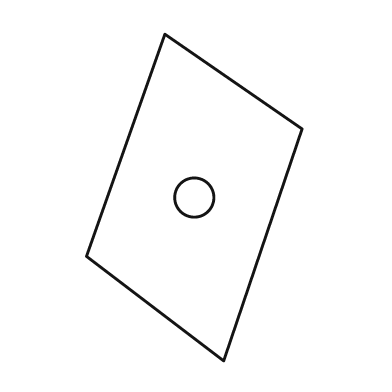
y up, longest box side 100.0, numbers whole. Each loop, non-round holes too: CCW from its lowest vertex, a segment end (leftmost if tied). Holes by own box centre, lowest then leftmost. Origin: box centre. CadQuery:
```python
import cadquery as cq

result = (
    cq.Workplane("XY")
    .moveTo(9.0, -50.0)
    .lineTo(33.0, 21.0)
    .lineTo(-9.0, 50.0)
    .lineTo(-33.0, -18.0)
    .close()
    .moveTo(0.0, 0.0)
    .circle(6.0)
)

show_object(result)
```